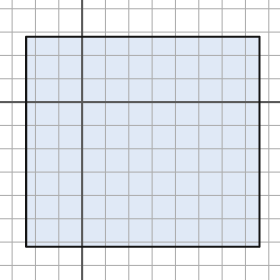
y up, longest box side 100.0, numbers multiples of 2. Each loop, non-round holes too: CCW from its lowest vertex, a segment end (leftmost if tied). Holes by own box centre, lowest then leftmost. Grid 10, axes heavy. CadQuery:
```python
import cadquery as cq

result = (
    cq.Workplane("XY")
    .moveTo(-24.0, -62.0)
    .lineTo(76.0, -62.0)
    .lineTo(76.0, 28.0)
    .lineTo(-24.0, 28.0)
    .close()
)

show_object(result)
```